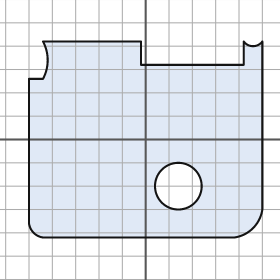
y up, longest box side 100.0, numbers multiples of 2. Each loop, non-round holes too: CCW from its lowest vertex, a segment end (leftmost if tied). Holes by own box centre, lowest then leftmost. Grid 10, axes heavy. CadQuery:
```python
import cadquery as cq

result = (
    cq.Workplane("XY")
    .moveTo(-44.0, -42.0)
    .lineTo(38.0, -42.0)
    .threePointArc((46.0, -38.0), (50.0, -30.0))
    .lineTo(50.0, 42.0)
    .threePointArc((46.0, 40.0), (42.0, 42.0))
    .lineTo(42.0, 32.0)
    .lineTo(-2.0, 32.0)
    .lineTo(-2.0, 42.0)
    .lineTo(-44.0, 42.0)
    .threePointArc((-42.0, 34.0), (-44.0, 26.0))
    .lineTo(-50.0, 26.0)
    .lineTo(-50.0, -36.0)
    .threePointArc((-48.0, -40.0), (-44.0, -42.0))
    .close()
    .moveTo(14.0, -20.0)
    .circle(10.0)
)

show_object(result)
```